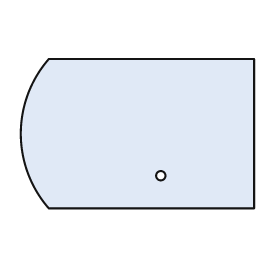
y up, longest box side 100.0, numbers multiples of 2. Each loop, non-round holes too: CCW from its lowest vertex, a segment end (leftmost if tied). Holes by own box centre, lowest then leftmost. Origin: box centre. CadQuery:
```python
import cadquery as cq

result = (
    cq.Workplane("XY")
    .moveTo(-38.0, -32.0)
    .lineTo(50.0, -32.0)
    .lineTo(50.0, 32.0)
    .lineTo(-38.0, 32.0)
    .threePointArc((-50.0, 0.0), (-38.0, -32.0))
    .close()
    .moveTo(10.0, -18.0)
    .circle(2.0)
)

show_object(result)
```